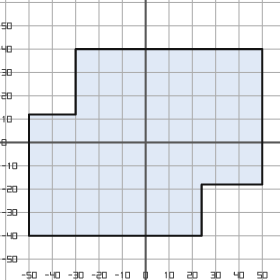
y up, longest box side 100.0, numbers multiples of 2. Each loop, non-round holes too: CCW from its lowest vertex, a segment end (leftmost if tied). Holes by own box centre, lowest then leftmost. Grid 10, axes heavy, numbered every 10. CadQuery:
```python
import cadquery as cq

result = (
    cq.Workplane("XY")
    .moveTo(-50.0, -40.0)
    .lineTo(24.0, -40.0)
    .lineTo(24.0, -18.0)
    .lineTo(50.0, -18.0)
    .lineTo(50.0, 40.0)
    .lineTo(-30.0, 40.0)
    .lineTo(-30.0, 12.0)
    .lineTo(-50.0, 12.0)
    .close()
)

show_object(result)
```